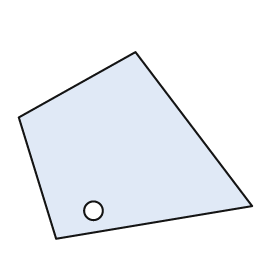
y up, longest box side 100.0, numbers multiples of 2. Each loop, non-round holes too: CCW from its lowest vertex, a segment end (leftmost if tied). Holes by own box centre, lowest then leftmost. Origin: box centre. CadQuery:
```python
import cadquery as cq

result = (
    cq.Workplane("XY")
    .moveTo(-34.0, -40.0)
    .lineTo(50.0, -26.0)
    .lineTo(0.0, 40.0)
    .lineTo(-50.0, 12.0)
    .close()
    .moveTo(-18.0, -28.0)
    .circle(4.0)
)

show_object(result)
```